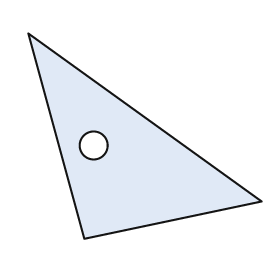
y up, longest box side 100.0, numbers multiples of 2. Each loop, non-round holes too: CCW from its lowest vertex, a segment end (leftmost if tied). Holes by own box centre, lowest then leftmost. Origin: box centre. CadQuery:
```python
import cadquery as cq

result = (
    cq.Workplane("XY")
    .moveTo(-26.0, -44.0)
    .lineTo(50.0, -28.0)
    .lineTo(-50.0, 44.0)
    .close()
    .moveTo(-22.0, -4.0)
    .circle(6.0)
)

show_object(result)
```